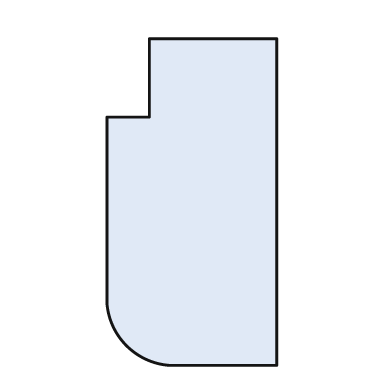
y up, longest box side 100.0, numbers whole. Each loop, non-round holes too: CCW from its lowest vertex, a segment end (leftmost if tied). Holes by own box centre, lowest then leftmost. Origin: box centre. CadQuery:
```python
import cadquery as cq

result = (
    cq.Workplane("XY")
    .moveTo(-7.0, -50.0)
    .lineTo(26.0, -50.0)
    .lineTo(26.0, 50.0)
    .lineTo(-13.0, 50.0)
    .lineTo(-13.0, 26.0)
    .lineTo(-26.0, 26.0)
    .lineTo(-26.0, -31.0)
    .threePointArc((-20.0, -44.0), (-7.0, -50.0))
    .close()
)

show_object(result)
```